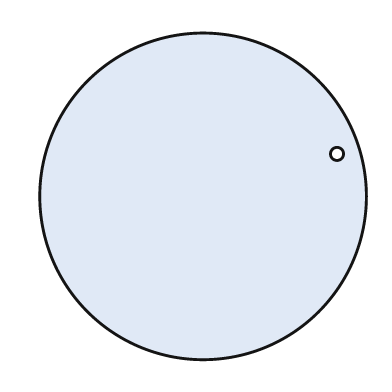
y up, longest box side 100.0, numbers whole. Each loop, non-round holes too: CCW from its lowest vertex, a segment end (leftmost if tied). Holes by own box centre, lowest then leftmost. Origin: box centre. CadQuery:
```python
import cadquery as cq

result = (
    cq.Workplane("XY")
    .moveTo(0.0, 0.0)
    .circle(50.0)
    .moveTo(41.0, 13.0)
    .circle(2.0)
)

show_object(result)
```